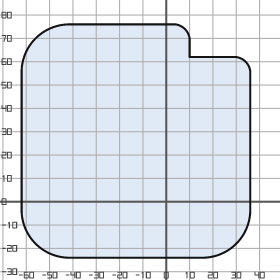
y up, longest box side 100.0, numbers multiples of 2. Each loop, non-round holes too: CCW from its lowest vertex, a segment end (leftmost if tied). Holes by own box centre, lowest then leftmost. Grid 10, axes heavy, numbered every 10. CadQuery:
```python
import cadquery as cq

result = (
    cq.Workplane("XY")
    .moveTo(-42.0, -24.0)
    .lineTo(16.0, -24.0)
    .threePointArc((30.0, -18.0), (36.0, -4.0))
    .lineTo(36.0, 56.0)
    .threePointArc((34.0, 60.0), (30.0, 62.0))
    .lineTo(10.0, 62.0)
    .lineTo(10.0, 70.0)
    .threePointArc((8.0, 74.0), (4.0, 76.0))
    .lineTo(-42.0, 76.0)
    .threePointArc((-56.0, 70.0), (-62.0, 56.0))
    .lineTo(-62.0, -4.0)
    .threePointArc((-56.0, -18.0), (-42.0, -24.0))
    .close()
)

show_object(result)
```